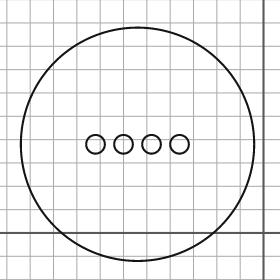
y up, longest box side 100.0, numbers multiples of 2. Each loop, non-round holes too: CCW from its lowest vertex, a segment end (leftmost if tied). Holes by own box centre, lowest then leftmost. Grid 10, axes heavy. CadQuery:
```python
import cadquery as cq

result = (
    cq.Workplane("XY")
    .moveTo(-54.0, 38.0)
    .circle(50.0)
    .moveTo(-72.0, 38.0)
    .circle(4.0)
    .moveTo(-60.0, 38.0)
    .circle(4.0)
    .moveTo(-48.0, 38.0)
    .circle(4.0)
    .moveTo(-36.0, 38.0)
    .circle(4.0)
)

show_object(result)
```